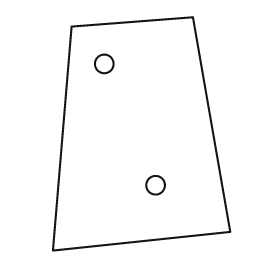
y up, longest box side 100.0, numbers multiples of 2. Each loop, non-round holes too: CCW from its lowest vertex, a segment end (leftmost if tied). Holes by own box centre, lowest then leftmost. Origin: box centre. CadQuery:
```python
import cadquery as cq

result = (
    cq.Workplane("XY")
    .moveTo(-38.0, -50.0)
    .lineTo(38.0, -42.0)
    .lineTo(22.0, 50.0)
    .lineTo(-30.0, 46.0)
    .close()
    .moveTo(6.0, -22.0)
    .circle(4.0)
    .moveTo(-16.0, 30.0)
    .circle(4.0)
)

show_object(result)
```